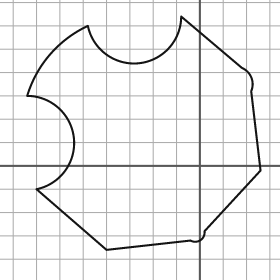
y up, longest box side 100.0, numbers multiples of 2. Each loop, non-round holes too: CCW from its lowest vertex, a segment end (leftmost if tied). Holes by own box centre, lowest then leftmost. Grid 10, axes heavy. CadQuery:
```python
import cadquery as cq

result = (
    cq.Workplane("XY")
    .moveTo(-40.0, -36.0)
    .lineTo(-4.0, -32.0)
    .threePointArc((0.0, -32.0), (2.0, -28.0))
    .lineTo(26.0, -2.0)
    .lineTo(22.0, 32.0)
    .threePointArc((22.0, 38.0), (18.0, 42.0))
    .lineTo(-8.0, 64.0)
    .threePointArc((-26.0, 44.0), (-48.0, 60.0))
    .threePointArc((-64.0, 48.0), (-74.0, 30.0))
    .threePointArc((-54.0, 12.0), (-70.0, -10.0))
    .close()
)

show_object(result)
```